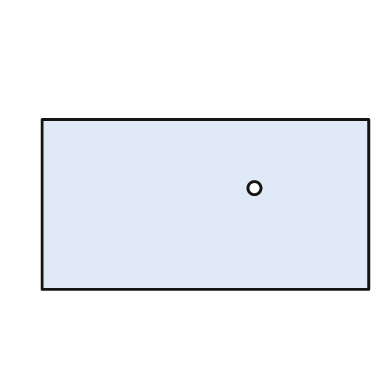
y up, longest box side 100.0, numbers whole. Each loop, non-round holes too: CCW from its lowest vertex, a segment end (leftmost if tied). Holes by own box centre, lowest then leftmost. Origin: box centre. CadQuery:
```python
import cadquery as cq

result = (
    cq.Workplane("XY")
    .moveTo(-50.0, -26.0)
    .lineTo(50.0, -26.0)
    .lineTo(50.0, 26.0)
    .lineTo(-50.0, 26.0)
    .close()
    .moveTo(15.0, 5.0)
    .circle(2.0)
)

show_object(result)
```